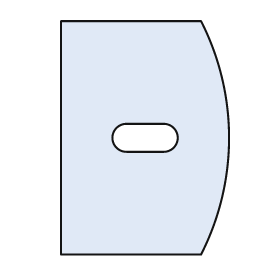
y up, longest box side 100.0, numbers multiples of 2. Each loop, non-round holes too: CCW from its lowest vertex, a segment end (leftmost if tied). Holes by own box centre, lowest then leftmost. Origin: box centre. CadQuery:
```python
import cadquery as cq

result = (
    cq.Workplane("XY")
    .moveTo(-36.0, -50.0)
    .lineTo(24.0, -50.0)
    .threePointArc((36.0, 0.0), (24.0, 50.0))
    .lineTo(-36.0, 50.0)
    .close()
    .moveTo(-8.0, -6.0)
    .lineTo(8.0, -6.0)
    .threePointArc((14.0, 0.0), (8.0, 6.0))
    .lineTo(-8.0, 6.0)
    .threePointArc((-14.0, 0.0), (-8.0, -6.0))
    .close()
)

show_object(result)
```